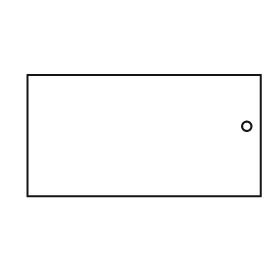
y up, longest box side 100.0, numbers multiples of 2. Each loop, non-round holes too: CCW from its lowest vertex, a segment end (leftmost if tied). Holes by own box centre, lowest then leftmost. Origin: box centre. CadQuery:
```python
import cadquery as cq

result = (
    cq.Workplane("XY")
    .moveTo(-50.0, -26.0)
    .lineTo(50.0, -26.0)
    .lineTo(50.0, 26.0)
    .lineTo(-50.0, 26.0)
    .close()
    .moveTo(44.0, 4.0)
    .circle(2.0)
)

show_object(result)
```